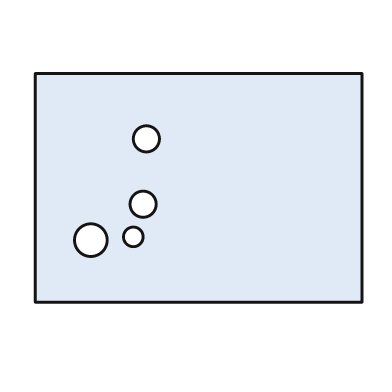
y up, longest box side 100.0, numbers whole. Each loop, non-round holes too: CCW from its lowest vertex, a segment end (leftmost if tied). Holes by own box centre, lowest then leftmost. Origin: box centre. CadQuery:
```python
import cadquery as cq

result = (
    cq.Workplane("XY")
    .moveTo(-50.0, -35.0)
    .lineTo(50.0, -35.0)
    .lineTo(50.0, 35.0)
    .lineTo(-50.0, 35.0)
    .close()
    .moveTo(-33.0, -16.0)
    .circle(5.0)
    .moveTo(-20.0, -15.0)
    .circle(3.0)
    .moveTo(-17.0, -5.0)
    .circle(4.0)
    .moveTo(-16.0, 15.0)
    .circle(4.0)
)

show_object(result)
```